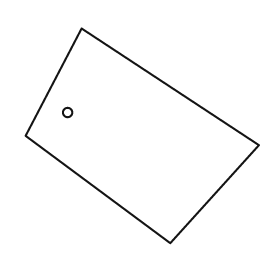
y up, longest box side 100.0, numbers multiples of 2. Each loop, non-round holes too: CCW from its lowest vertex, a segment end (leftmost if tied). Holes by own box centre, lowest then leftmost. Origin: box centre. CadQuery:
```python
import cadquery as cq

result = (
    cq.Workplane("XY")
    .moveTo(12.0, -46.0)
    .lineTo(50.0, -4.0)
    .lineTo(-26.0, 46.0)
    .lineTo(-50.0, 0.0)
    .close()
    .moveTo(-32.0, 10.0)
    .circle(2.0)
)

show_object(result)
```